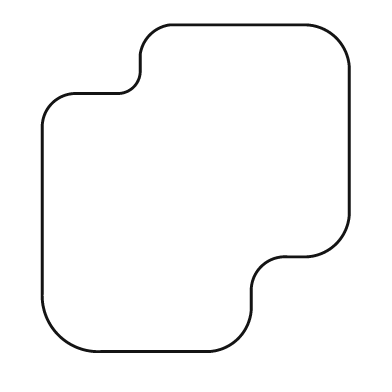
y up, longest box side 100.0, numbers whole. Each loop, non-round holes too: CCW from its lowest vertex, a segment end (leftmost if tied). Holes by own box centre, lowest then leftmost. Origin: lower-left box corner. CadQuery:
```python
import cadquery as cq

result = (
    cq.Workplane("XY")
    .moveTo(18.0, 0.0)
    .lineTo(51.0, 0.0)
    .threePointArc((60.0, 4.0), (64.0, 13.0))
    .lineTo(64.0, 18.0)
    .threePointArc((67.0, 26.0), (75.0, 29.0))
    .lineTo(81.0, 29.0)
    .threePointArc((90.0, 33.0), (94.0, 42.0))
    .lineTo(94.0, 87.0)
    .threePointArc((90.0, 96.0), (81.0, 100.0))
    .lineTo(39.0, 100.0)
    .threePointArc((33.0, 97.0), (30.0, 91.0))
    .lineTo(30.0, 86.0)
    .threePointArc((28.0, 81.0), (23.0, 79.0))
    .lineTo(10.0, 79.0)
    .threePointArc((3.0, 76.0), (0.0, 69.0))
    .lineTo(0.0, 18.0)
    .threePointArc((5.0, 5.0), (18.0, 0.0))
    .close()
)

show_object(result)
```